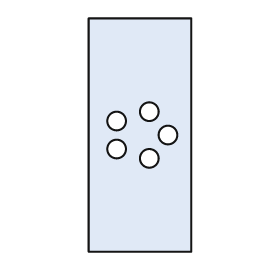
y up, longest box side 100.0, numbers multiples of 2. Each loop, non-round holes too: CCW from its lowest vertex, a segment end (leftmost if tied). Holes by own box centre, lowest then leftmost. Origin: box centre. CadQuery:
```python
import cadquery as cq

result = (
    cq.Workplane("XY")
    .moveTo(-22.0, -50.0)
    .lineTo(22.0, -50.0)
    .lineTo(22.0, 50.0)
    .lineTo(-22.0, 50.0)
    .close()
    .moveTo(4.0, -10.0)
    .circle(4.0)
    .moveTo(-10.0, -6.0)
    .circle(4.0)
    .moveTo(12.0, 0.0)
    .circle(4.0)
    .moveTo(-10.0, 6.0)
    .circle(4.0)
    .moveTo(4.0, 10.0)
    .circle(4.0)
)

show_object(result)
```